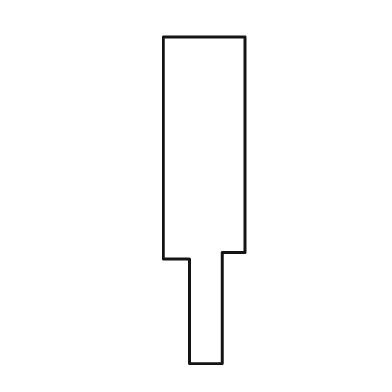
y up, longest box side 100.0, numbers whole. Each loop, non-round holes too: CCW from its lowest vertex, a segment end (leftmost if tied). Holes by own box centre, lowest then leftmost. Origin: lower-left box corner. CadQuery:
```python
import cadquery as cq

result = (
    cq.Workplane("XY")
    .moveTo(8.0, 0.0)
    .lineTo(18.0, 0.0)
    .lineTo(18.0, 34.0)
    .lineTo(25.0, 34.0)
    .lineTo(25.0, 100.0)
    .lineTo(0.0, 100.0)
    .lineTo(0.0, 32.0)
    .lineTo(8.0, 32.0)
    .close()
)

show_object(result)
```